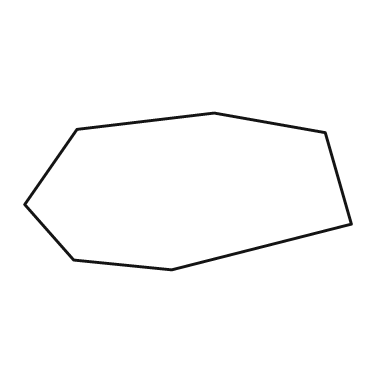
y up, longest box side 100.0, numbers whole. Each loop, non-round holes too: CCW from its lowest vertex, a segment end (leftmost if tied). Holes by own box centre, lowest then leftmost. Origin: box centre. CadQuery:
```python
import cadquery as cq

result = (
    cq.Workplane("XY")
    .moveTo(-5.0, -24.0)
    .lineTo(50.0, -10.0)
    .lineTo(42.0, 18.0)
    .lineTo(8.0, 24.0)
    .lineTo(-34.0, 19.0)
    .lineTo(-50.0, -4.0)
    .lineTo(-35.0, -21.0)
    .close()
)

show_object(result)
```